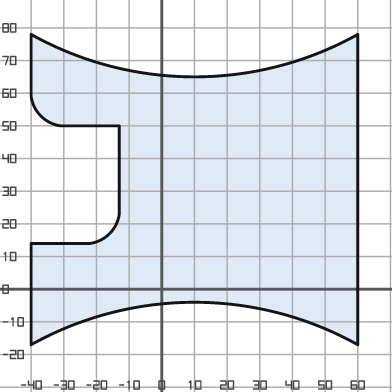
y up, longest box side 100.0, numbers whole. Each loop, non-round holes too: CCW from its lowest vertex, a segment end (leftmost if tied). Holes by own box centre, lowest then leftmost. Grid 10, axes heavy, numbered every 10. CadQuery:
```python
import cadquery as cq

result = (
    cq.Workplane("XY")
    .moveTo(-40.0, -17.0)
    .threePointArc((10.0, -4.0), (60.0, -17.0))
    .lineTo(60.0, 78.0)
    .threePointArc((10.0, 65.0), (-40.0, 78.0))
    .lineTo(-40.0, 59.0)
    .threePointArc((-37.0, 53.0), (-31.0, 50.0))
    .lineTo(-13.0, 50.0)
    .lineTo(-13.0, 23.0)
    .threePointArc((-16.0, 17.0), (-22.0, 14.0))
    .lineTo(-40.0, 14.0)
    .close()
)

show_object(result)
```